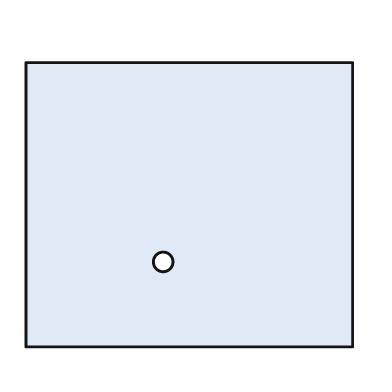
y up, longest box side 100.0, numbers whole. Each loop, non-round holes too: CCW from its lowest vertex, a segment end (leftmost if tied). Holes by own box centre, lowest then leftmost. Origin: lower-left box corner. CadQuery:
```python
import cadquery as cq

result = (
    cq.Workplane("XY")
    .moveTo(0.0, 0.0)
    .lineTo(100.0, 0.0)
    .lineTo(100.0, 87.0)
    .lineTo(0.0, 87.0)
    .close()
    .moveTo(42.0, 26.0)
    .circle(3.0)
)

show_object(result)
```